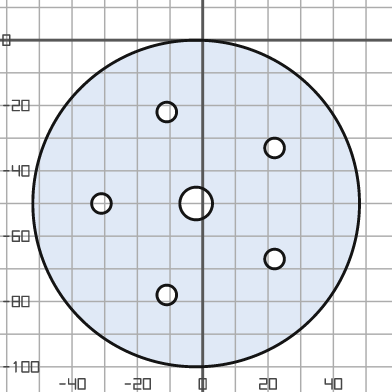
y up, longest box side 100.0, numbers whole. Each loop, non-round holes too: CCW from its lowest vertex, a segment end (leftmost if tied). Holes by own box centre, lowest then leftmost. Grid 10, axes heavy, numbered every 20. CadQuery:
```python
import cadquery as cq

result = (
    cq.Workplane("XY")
    .moveTo(-2.0, -50.0)
    .circle(50.0)
    .moveTo(-11.0, -78.0)
    .circle(3.0)
    .moveTo(22.0, -67.0)
    .circle(3.0)
    .moveTo(-31.0, -50.0)
    .circle(3.0)
    .moveTo(-2.0, -50.0)
    .circle(5.0)
    .moveTo(22.0, -33.0)
    .circle(3.0)
    .moveTo(-11.0, -22.0)
    .circle(3.0)
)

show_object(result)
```